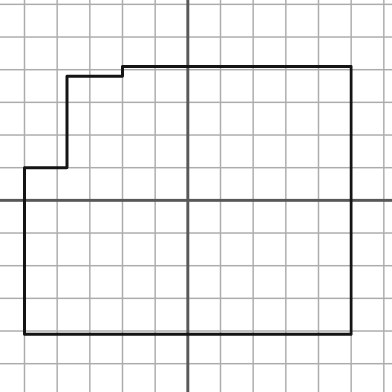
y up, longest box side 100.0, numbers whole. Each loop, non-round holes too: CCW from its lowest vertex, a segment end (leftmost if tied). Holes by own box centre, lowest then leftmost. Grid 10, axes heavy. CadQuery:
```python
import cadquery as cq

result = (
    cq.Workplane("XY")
    .moveTo(-50.0, -41.0)
    .lineTo(50.0, -41.0)
    .lineTo(50.0, 41.0)
    .lineTo(-20.0, 41.0)
    .lineTo(-20.0, 38.0)
    .lineTo(-37.0, 38.0)
    .lineTo(-37.0, 10.0)
    .lineTo(-50.0, 10.0)
    .close()
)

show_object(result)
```